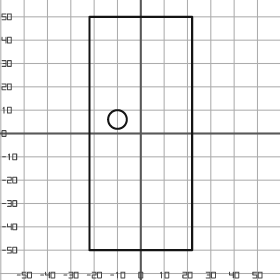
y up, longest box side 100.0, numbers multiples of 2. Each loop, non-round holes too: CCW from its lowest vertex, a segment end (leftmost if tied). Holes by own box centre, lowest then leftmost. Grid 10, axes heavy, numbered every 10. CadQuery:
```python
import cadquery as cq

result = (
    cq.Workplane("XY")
    .moveTo(-22.0, -50.0)
    .lineTo(22.0, -50.0)
    .lineTo(22.0, 50.0)
    .lineTo(-22.0, 50.0)
    .close()
    .moveTo(-10.0, 6.0)
    .circle(4.0)
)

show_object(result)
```